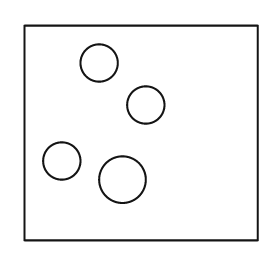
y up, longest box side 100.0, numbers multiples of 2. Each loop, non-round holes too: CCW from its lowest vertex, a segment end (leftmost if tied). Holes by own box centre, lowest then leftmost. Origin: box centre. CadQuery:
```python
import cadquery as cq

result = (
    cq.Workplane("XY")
    .moveTo(-50.0, -46.0)
    .lineTo(50.0, -46.0)
    .lineTo(50.0, 46.0)
    .lineTo(-50.0, 46.0)
    .close()
    .moveTo(-8.0, -20.0)
    .circle(10.0)
    .moveTo(-34.0, -12.0)
    .circle(8.0)
    .moveTo(2.0, 12.0)
    .circle(8.0)
    .moveTo(-18.0, 30.0)
    .circle(8.0)
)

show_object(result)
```